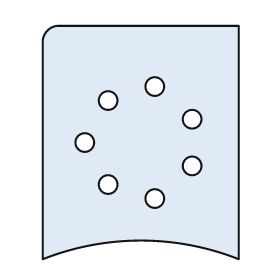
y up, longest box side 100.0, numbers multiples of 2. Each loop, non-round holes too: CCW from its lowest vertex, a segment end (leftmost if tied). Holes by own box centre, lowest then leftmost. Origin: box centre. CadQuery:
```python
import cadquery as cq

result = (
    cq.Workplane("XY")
    .moveTo(-42.0, -50.0)
    .threePointArc((0.0, -42.0), (42.0, -50.0))
    .lineTo(42.0, 50.0)
    .lineTo(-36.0, 50.0)
    .threePointArc((-40.0, 48.0), (-42.0, 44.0))
    .close()
    .moveTo(6.0, -24.0)
    .circle(4.0)
    .moveTo(-14.0, -18.0)
    .circle(4.0)
    .moveTo(22.0, -10.0)
    .circle(4.0)
    .moveTo(-24.0, 0.0)
    .circle(4.0)
    .moveTo(22.0, 10.0)
    .circle(4.0)
    .moveTo(-14.0, 18.0)
    .circle(4.0)
    .moveTo(6.0, 24.0)
    .circle(4.0)
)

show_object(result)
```